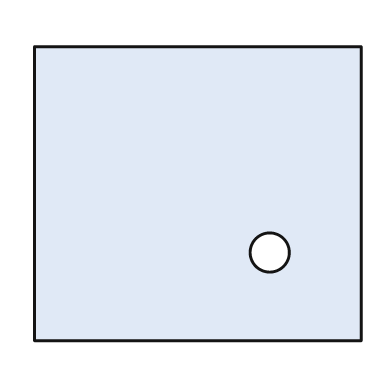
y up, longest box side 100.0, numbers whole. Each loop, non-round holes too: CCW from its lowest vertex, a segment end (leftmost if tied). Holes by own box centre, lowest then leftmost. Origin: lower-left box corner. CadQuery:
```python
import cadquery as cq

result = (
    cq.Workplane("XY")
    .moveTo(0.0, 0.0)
    .lineTo(100.0, 0.0)
    .lineTo(100.0, 90.0)
    .lineTo(0.0, 90.0)
    .close()
    .moveTo(72.0, 27.0)
    .circle(6.0)
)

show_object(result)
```